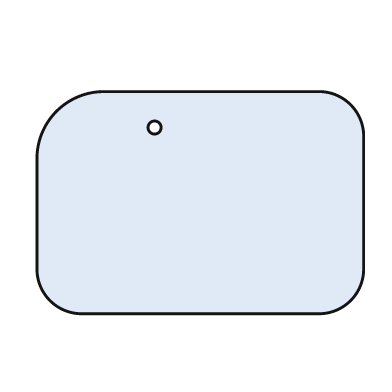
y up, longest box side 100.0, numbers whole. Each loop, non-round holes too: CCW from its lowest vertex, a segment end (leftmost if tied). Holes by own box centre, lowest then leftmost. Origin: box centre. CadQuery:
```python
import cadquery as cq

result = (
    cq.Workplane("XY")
    .moveTo(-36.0, -34.0)
    .lineTo(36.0, -34.0)
    .threePointArc((46.0, -30.0), (50.0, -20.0))
    .lineTo(50.0, 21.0)
    .threePointArc((46.0, 30.0), (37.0, 34.0))
    .lineTo(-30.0, 34.0)
    .threePointArc((-44.0, 28.0), (-50.0, 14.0))
    .lineTo(-50.0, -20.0)
    .threePointArc((-46.0, -30.0), (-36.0, -34.0))
    .close()
    .moveTo(-14.0, 23.0)
    .circle(2.0)
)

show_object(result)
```